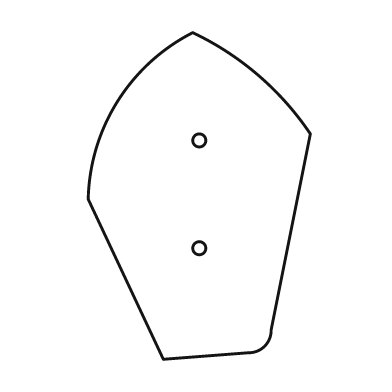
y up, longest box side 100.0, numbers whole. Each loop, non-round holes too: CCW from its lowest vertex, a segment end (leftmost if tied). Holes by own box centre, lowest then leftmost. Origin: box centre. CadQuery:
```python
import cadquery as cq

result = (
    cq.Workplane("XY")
    .moveTo(-11.0, -50.0)
    .lineTo(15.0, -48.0)
    .threePointArc((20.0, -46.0), (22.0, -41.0))
    .lineTo(34.0, 19.0)
    .threePointArc((18.0, 37.0), (-2.0, 50.0))
    .threePointArc((-25.0, 29.0), (-34.0, -1.0))
    .close()
    .moveTo(0.0, -16.0)
    .circle(2.0)
    .moveTo(0.0, 17.0)
    .circle(2.0)
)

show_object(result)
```